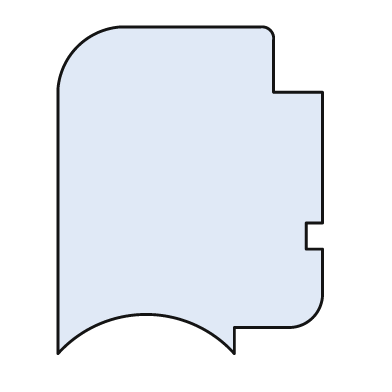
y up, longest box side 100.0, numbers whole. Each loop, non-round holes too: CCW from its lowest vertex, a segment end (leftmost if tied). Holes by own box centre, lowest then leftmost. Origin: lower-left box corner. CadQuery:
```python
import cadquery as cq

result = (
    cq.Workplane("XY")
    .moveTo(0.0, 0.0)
    .threePointArc((27.0, 12.0), (54.0, 0.0))
    .lineTo(54.0, 8.0)
    .lineTo(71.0, 8.0)
    .threePointArc((78.0, 11.0), (81.0, 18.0))
    .lineTo(81.0, 32.0)
    .lineTo(76.0, 32.0)
    .lineTo(76.0, 40.0)
    .lineTo(81.0, 40.0)
    .lineTo(81.0, 80.0)
    .lineTo(66.0, 80.0)
    .lineTo(66.0, 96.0)
    .threePointArc((65.0, 99.0), (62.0, 100.0))
    .lineTo(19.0, 100.0)
    .threePointArc((6.0, 94.0), (0.0, 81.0))
    .close()
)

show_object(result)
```